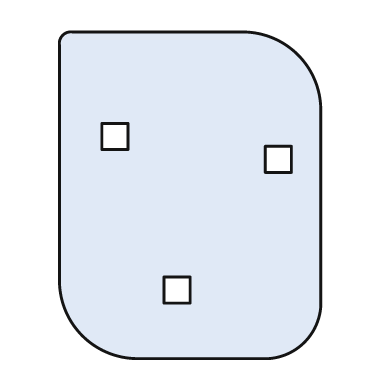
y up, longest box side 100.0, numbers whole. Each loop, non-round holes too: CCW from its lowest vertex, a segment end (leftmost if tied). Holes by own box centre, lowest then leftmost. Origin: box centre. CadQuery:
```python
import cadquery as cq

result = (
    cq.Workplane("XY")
    .moveTo(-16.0, -50.0)
    .lineTo(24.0, -50.0)
    .threePointArc((35.0, -45.0), (40.0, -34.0))
    .lineTo(40.0, 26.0)
    .threePointArc((33.0, 43.0), (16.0, 50.0))
    .lineTo(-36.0, 50.0)
    .threePointArc((-39.0, 49.0), (-40.0, 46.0))
    .lineTo(-40.0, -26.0)
    .threePointArc((-33.0, -43.0), (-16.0, -50.0))
    .close()
    .moveTo(-8.0, -33.0)
    .lineTo(0.0, -33.0)
    .lineTo(0.0, -25.0)
    .lineTo(-8.0, -25.0)
    .close()
    .moveTo(23.0, 7.0)
    .lineTo(31.0, 7.0)
    .lineTo(31.0, 15.0)
    .lineTo(23.0, 15.0)
    .close()
    .moveTo(-27.0, 14.0)
    .lineTo(-19.0, 14.0)
    .lineTo(-19.0, 22.0)
    .lineTo(-27.0, 22.0)
    .close()
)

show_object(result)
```